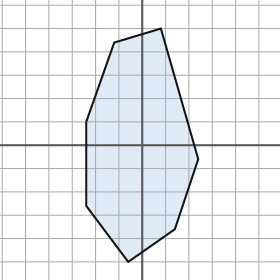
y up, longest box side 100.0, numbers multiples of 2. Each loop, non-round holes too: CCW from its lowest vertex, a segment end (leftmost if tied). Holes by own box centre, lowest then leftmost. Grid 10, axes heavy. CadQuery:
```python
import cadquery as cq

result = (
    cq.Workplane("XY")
    .moveTo(-6.0, -50.0)
    .lineTo(14.0, -36.0)
    .lineTo(24.0, -6.0)
    .lineTo(8.0, 50.0)
    .lineTo(-12.0, 44.0)
    .lineTo(-24.0, 10.0)
    .lineTo(-24.0, -26.0)
    .close()
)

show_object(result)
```